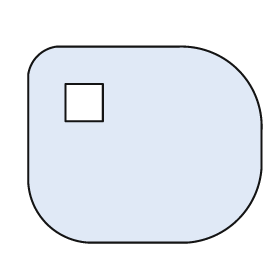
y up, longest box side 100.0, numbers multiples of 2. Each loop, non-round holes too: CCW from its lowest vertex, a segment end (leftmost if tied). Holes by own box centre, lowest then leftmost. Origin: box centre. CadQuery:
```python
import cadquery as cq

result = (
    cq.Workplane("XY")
    .moveTo(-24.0, -42.0)
    .lineTo(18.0, -42.0)
    .threePointArc((40.0, -32.0), (50.0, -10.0))
    .lineTo(50.0, 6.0)
    .threePointArc((40.0, 32.0), (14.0, 42.0))
    .lineTo(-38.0, 42.0)
    .threePointArc((-46.0, 38.0), (-50.0, 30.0))
    .lineTo(-50.0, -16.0)
    .threePointArc((-42.0, -34.0), (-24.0, -42.0))
    .close()
    .moveTo(-34.0, 10.0)
    .lineTo(-18.0, 10.0)
    .lineTo(-18.0, 26.0)
    .lineTo(-34.0, 26.0)
    .close()
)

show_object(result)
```